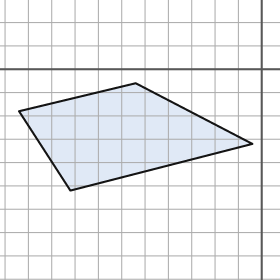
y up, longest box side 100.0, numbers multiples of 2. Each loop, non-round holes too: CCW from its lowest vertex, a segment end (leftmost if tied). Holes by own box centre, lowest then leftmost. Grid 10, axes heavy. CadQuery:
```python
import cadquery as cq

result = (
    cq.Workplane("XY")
    .moveTo(-82.0, -52.0)
    .lineTo(-4.0, -32.0)
    .lineTo(-54.0, -6.0)
    .lineTo(-104.0, -18.0)
    .close()
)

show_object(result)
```